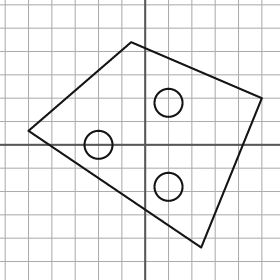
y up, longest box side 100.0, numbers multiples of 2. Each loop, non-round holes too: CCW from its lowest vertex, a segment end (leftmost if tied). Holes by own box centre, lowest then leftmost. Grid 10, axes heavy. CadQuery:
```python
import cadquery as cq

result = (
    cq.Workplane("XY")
    .moveTo(24.0, -44.0)
    .lineTo(50.0, 20.0)
    .lineTo(-6.0, 44.0)
    .lineTo(-50.0, 6.0)
    .close()
    .moveTo(10.0, -18.0)
    .circle(6.0)
    .moveTo(-20.0, 0.0)
    .circle(6.0)
    .moveTo(10.0, 18.0)
    .circle(6.0)
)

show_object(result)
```